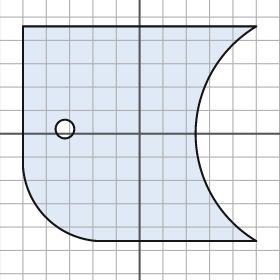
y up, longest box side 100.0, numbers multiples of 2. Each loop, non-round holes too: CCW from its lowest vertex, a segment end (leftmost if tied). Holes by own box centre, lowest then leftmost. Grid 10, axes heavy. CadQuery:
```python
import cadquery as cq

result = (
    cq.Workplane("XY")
    .moveTo(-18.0, -46.0)
    .lineTo(50.0, -46.0)
    .threePointArc((24.0, 0.0), (50.0, 46.0))
    .lineTo(-50.0, 46.0)
    .lineTo(-50.0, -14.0)
    .threePointArc((-40.0, -36.0), (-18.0, -46.0))
    .close()
    .moveTo(-32.0, 2.0)
    .circle(4.0)
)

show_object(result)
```